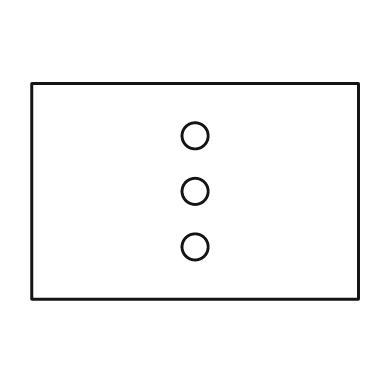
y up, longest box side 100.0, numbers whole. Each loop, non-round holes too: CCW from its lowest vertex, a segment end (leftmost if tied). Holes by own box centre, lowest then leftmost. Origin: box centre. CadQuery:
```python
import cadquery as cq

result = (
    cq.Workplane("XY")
    .moveTo(-50.0, -33.0)
    .lineTo(50.0, -33.0)
    .lineTo(50.0, 33.0)
    .lineTo(-50.0, 33.0)
    .close()
    .moveTo(0.0, -17.0)
    .circle(4.0)
    .moveTo(0.0, 0.0)
    .circle(4.0)
    .moveTo(0.0, 17.0)
    .circle(4.0)
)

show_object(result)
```